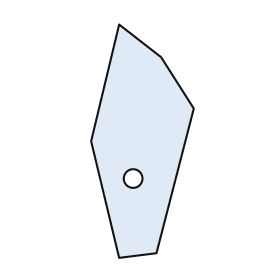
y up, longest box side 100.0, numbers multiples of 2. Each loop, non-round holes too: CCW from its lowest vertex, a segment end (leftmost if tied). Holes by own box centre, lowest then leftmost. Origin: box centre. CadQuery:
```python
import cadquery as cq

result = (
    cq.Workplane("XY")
    .moveTo(-10.0, -50.0)
    .lineTo(6.0, -48.0)
    .lineTo(22.0, 14.0)
    .lineTo(8.0, 36.0)
    .lineTo(-10.0, 50.0)
    .lineTo(-22.0, 0.0)
    .close()
    .moveTo(-4.0, -16.0)
    .circle(4.0)
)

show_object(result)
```